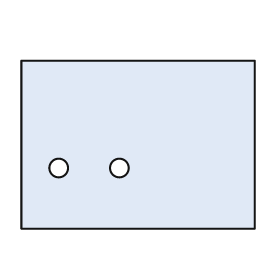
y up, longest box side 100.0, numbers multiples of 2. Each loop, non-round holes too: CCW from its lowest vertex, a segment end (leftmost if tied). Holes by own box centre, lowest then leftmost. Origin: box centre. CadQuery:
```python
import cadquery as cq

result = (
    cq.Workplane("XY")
    .moveTo(-50.0, -36.0)
    .lineTo(50.0, -36.0)
    .lineTo(50.0, 36.0)
    .lineTo(-50.0, 36.0)
    .close()
    .moveTo(-34.0, -10.0)
    .circle(4.0)
    .moveTo(-8.0, -10.0)
    .circle(4.0)
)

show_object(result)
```